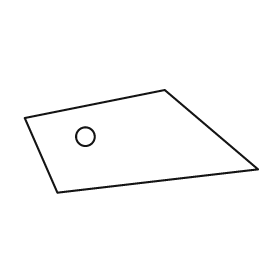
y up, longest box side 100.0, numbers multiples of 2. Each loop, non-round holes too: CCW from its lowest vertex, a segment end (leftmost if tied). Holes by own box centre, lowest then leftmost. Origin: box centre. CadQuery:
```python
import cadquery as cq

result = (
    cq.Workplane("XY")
    .moveTo(-36.0, -22.0)
    .lineTo(50.0, -12.0)
    .lineTo(10.0, 22.0)
    .lineTo(-50.0, 10.0)
    .close()
    .moveTo(-24.0, 2.0)
    .circle(4.0)
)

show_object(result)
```